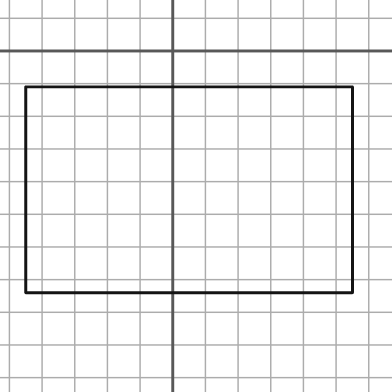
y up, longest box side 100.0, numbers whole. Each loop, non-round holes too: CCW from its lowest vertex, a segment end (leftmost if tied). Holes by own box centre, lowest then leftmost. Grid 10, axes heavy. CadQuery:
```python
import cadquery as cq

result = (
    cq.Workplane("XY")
    .moveTo(-45.0, -74.0)
    .lineTo(55.0, -74.0)
    .lineTo(55.0, -11.0)
    .lineTo(-45.0, -11.0)
    .close()
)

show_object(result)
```